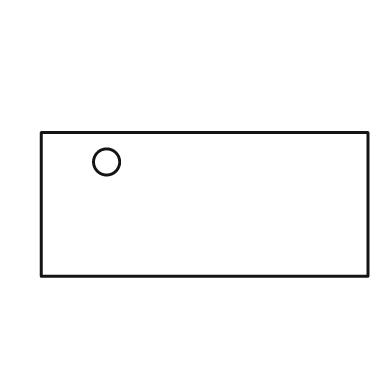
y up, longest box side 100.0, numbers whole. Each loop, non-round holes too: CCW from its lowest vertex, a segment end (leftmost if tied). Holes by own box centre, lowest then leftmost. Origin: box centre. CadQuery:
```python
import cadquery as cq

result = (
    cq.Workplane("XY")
    .moveTo(-50.0, -22.0)
    .lineTo(50.0, -22.0)
    .lineTo(50.0, 22.0)
    .lineTo(-50.0, 22.0)
    .close()
    .moveTo(-30.0, 13.0)
    .circle(4.0)
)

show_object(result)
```